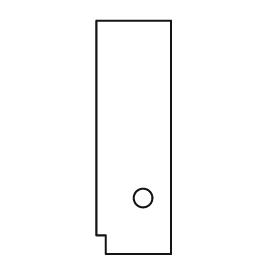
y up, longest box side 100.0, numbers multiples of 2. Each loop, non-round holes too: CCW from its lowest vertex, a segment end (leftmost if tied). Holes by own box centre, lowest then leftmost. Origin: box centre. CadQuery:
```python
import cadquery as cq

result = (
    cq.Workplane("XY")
    .moveTo(-12.0, -50.0)
    .lineTo(16.0, -50.0)
    .lineTo(16.0, 50.0)
    .lineTo(-16.0, 50.0)
    .lineTo(-16.0, -42.0)
    .lineTo(-12.0, -42.0)
    .close()
    .moveTo(4.0, -26.0)
    .circle(4.0)
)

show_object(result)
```